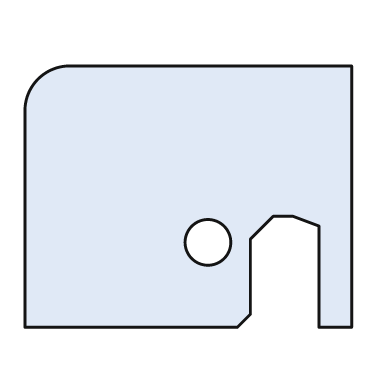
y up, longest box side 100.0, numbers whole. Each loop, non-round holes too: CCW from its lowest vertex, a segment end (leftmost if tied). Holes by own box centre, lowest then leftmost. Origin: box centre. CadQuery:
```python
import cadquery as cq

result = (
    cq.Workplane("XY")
    .moveTo(-50.0, -40.0)
    .lineTo(15.0, -40.0)
    .lineTo(19.0, -36.0)
    .lineTo(19.0, -13.0)
    .lineTo(26.0, -6.0)
    .lineTo(32.0, -6.0)
    .lineTo(40.0, -9.0)
    .lineTo(40.0, -40.0)
    .lineTo(50.0, -40.0)
    .lineTo(50.0, 40.0)
    .lineTo(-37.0, 40.0)
    .threePointArc((-46.0, 36.0), (-50.0, 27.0))
    .close()
    .moveTo(6.0, -14.0)
    .circle(7.0)
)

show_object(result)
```